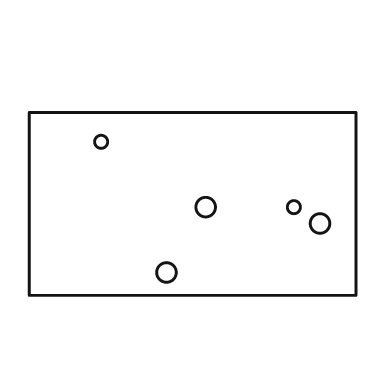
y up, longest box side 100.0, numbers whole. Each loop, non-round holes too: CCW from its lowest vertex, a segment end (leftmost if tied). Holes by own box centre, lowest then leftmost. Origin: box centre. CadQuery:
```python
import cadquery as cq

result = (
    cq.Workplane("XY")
    .moveTo(-50.0, -28.0)
    .lineTo(50.0, -28.0)
    .lineTo(50.0, 28.0)
    .lineTo(-50.0, 28.0)
    .close()
    .moveTo(-8.0, -21.0)
    .circle(3.0)
    .moveTo(39.0, -6.0)
    .circle(3.0)
    .moveTo(4.0, -1.0)
    .circle(3.0)
    .moveTo(31.0, -1.0)
    .circle(2.0)
    .moveTo(-28.0, 19.0)
    .circle(2.0)
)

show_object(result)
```